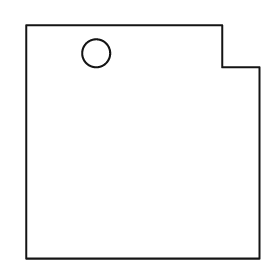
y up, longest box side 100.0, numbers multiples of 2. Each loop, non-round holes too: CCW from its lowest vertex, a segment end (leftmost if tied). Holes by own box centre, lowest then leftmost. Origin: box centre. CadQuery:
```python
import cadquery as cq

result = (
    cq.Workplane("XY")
    .moveTo(-50.0, -50.0)
    .lineTo(50.0, -50.0)
    .lineTo(50.0, 32.0)
    .lineTo(34.0, 32.0)
    .lineTo(34.0, 50.0)
    .lineTo(-50.0, 50.0)
    .close()
    .moveTo(-20.0, 38.0)
    .circle(6.0)
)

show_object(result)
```